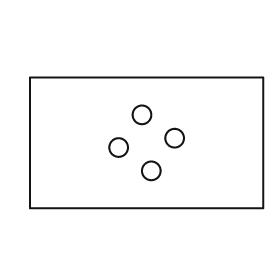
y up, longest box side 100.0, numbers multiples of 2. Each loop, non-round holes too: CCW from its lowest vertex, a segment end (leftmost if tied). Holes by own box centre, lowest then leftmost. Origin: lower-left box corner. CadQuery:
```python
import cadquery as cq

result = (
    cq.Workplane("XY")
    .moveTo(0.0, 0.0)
    .lineTo(100.0, 0.0)
    .lineTo(100.0, 56.0)
    .lineTo(0.0, 56.0)
    .close()
    .moveTo(52.0, 16.0)
    .circle(4.0)
    .moveTo(38.0, 26.0)
    .circle(4.0)
    .moveTo(62.0, 30.0)
    .circle(4.0)
    .moveTo(48.0, 40.0)
    .circle(4.0)
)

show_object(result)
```